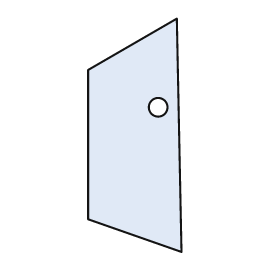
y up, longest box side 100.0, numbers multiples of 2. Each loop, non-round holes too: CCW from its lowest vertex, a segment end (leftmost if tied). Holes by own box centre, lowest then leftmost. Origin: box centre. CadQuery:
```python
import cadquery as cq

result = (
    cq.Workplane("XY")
    .moveTo(20.0, -50.0)
    .lineTo(18.0, 50.0)
    .lineTo(-20.0, 28.0)
    .lineTo(-20.0, -36.0)
    .close()
    .moveTo(10.0, 12.0)
    .circle(4.0)
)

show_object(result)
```